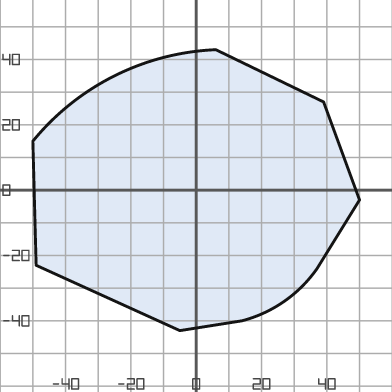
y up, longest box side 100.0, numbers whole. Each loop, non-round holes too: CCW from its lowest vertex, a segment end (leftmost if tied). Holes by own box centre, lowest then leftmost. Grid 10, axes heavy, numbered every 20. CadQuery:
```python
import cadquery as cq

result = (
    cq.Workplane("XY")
    .moveTo(-5.0, -43.0)
    .lineTo(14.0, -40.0)
    .threePointArc((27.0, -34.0), (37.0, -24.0))
    .lineTo(50.0, -3.0)
    .lineTo(39.0, 27.0)
    .lineTo(6.0, 43.0)
    .threePointArc((-25.0, 35.0), (-50.0, 15.0))
    .lineTo(-49.0, -23.0)
    .close()
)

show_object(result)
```